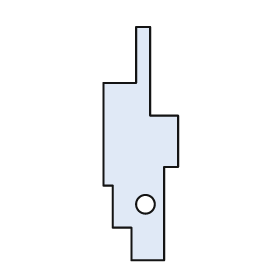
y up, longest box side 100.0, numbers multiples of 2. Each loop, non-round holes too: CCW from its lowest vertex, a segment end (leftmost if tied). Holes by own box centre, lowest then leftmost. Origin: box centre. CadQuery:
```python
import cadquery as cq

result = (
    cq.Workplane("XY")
    .moveTo(-4.0, -50.0)
    .lineTo(10.0, -50.0)
    .lineTo(10.0, -10.0)
    .lineTo(16.0, -10.0)
    .lineTo(16.0, 12.0)
    .lineTo(4.0, 12.0)
    .lineTo(4.0, 50.0)
    .lineTo(-2.0, 50.0)
    .lineTo(-2.0, 26.0)
    .lineTo(-16.0, 26.0)
    .lineTo(-16.0, -18.0)
    .lineTo(-12.0, -18.0)
    .lineTo(-12.0, -36.0)
    .lineTo(-4.0, -36.0)
    .close()
    .moveTo(2.0, -26.0)
    .circle(4.0)
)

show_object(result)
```